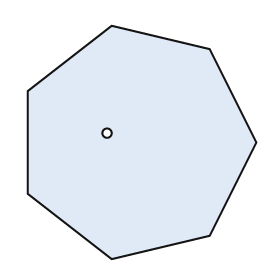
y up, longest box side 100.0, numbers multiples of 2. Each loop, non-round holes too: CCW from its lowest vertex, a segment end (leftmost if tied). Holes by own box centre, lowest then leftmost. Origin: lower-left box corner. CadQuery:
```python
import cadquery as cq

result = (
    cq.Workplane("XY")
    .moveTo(36.0, 0.0)
    .lineTo(78.0, 10.0)
    .lineTo(98.0, 50.0)
    .lineTo(78.0, 90.0)
    .lineTo(36.0, 100.0)
    .lineTo(0.0, 72.0)
    .lineTo(0.0, 28.0)
    .close()
    .moveTo(34.0, 54.0)
    .circle(2.0)
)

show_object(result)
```